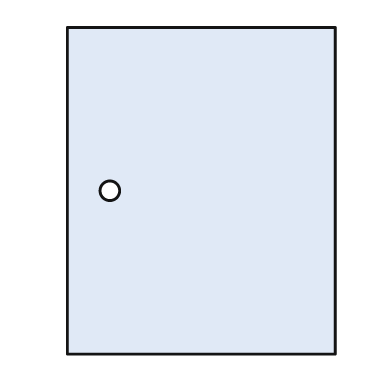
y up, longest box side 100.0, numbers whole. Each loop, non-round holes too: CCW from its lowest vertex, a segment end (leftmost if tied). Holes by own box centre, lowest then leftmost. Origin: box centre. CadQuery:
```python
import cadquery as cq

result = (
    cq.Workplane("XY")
    .moveTo(-41.0, -50.0)
    .lineTo(41.0, -50.0)
    .lineTo(41.0, 50.0)
    .lineTo(-41.0, 50.0)
    .close()
    .moveTo(-28.0, 0.0)
    .circle(3.0)
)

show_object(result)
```